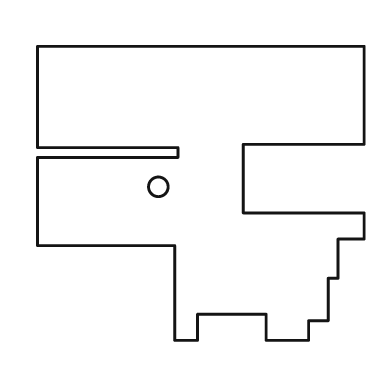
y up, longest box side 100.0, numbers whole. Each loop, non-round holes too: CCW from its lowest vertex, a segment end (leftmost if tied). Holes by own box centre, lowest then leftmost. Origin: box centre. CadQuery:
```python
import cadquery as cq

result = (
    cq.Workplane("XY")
    .moveTo(-8.0, -45.0)
    .lineTo(-1.0, -45.0)
    .lineTo(-1.0, -37.0)
    .lineTo(20.0, -37.0)
    .lineTo(20.0, -45.0)
    .lineTo(33.0, -45.0)
    .lineTo(33.0, -39.0)
    .lineTo(39.0, -39.0)
    .lineTo(39.0, -26.0)
    .lineTo(42.0, -26.0)
    .lineTo(42.0, -14.0)
    .lineTo(50.0, -14.0)
    .lineTo(50.0, -6.0)
    .lineTo(13.0, -6.0)
    .lineTo(13.0, 15.0)
    .lineTo(50.0, 15.0)
    .lineTo(50.0, 45.0)
    .lineTo(-50.0, 45.0)
    .lineTo(-50.0, 14.0)
    .lineTo(-7.0, 14.0)
    .lineTo(-7.0, 11.0)
    .lineTo(-50.0, 11.0)
    .lineTo(-50.0, -16.0)
    .lineTo(-8.0, -16.0)
    .close()
    .moveTo(-13.0, 2.0)
    .circle(3.0)
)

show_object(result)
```